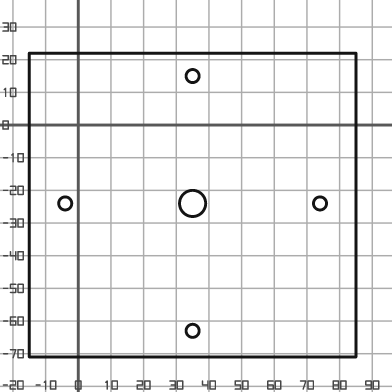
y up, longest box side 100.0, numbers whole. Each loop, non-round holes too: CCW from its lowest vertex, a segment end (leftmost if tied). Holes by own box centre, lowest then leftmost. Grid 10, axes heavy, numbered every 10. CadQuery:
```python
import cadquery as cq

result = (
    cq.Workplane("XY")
    .moveTo(-15.0, -71.0)
    .lineTo(85.0, -71.0)
    .lineTo(85.0, 22.0)
    .lineTo(-15.0, 22.0)
    .close()
    .moveTo(35.0, -63.0)
    .circle(2.0)
    .moveTo(-4.0, -24.0)
    .circle(2.0)
    .moveTo(35.0, -24.0)
    .circle(4.0)
    .moveTo(74.0, -24.0)
    .circle(2.0)
    .moveTo(35.0, 15.0)
    .circle(2.0)
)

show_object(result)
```